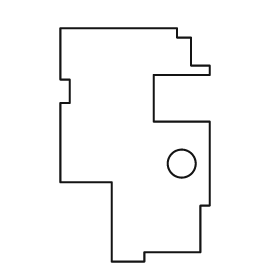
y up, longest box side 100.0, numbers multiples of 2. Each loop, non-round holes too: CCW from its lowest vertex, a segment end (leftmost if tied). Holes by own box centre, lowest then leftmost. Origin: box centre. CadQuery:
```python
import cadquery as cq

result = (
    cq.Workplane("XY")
    .moveTo(-10.0, -50.0)
    .lineTo(4.0, -50.0)
    .lineTo(4.0, -46.0)
    .lineTo(28.0, -46.0)
    .lineTo(28.0, -26.0)
    .lineTo(32.0, -26.0)
    .lineTo(32.0, 10.0)
    .lineTo(8.0, 10.0)
    .lineTo(8.0, 30.0)
    .lineTo(32.0, 30.0)
    .lineTo(32.0, 34.0)
    .lineTo(24.0, 34.0)
    .lineTo(24.0, 46.0)
    .lineTo(18.0, 46.0)
    .lineTo(18.0, 50.0)
    .lineTo(-32.0, 50.0)
    .lineTo(-32.0, 28.0)
    .lineTo(-28.0, 28.0)
    .lineTo(-28.0, 18.0)
    .lineTo(-32.0, 18.0)
    .lineTo(-32.0, -16.0)
    .lineTo(-10.0, -16.0)
    .close()
    .moveTo(20.0, -8.0)
    .circle(6.0)
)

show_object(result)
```